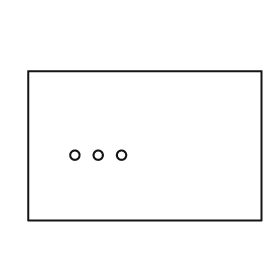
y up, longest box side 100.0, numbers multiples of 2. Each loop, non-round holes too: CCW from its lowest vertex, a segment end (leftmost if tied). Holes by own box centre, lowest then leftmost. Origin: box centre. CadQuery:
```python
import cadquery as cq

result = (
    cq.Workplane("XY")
    .moveTo(-50.0, -32.0)
    .lineTo(50.0, -32.0)
    .lineTo(50.0, 32.0)
    .lineTo(-50.0, 32.0)
    .close()
    .moveTo(-30.0, -4.0)
    .circle(2.0)
    .moveTo(-20.0, -4.0)
    .circle(2.0)
    .moveTo(-10.0, -4.0)
    .circle(2.0)
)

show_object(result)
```